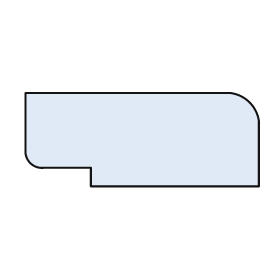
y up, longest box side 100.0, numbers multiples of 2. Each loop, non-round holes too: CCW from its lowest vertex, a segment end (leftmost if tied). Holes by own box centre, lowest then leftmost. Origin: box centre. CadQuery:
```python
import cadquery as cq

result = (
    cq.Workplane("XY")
    .moveTo(-22.0, -20.0)
    .lineTo(50.0, -20.0)
    .lineTo(50.0, 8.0)
    .threePointArc((46.0, 16.0), (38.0, 20.0))
    .lineTo(-50.0, 20.0)
    .lineTo(-50.0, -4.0)
    .threePointArc((-48.0, -10.0), (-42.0, -12.0))
    .lineTo(-22.0, -12.0)
    .close()
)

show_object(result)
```